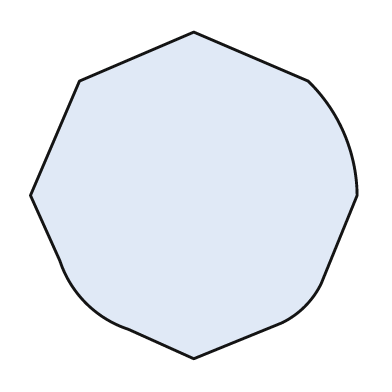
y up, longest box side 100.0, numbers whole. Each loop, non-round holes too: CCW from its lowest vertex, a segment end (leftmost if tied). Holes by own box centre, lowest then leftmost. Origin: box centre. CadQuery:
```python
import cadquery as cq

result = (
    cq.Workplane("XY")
    .moveTo(0.0, -50.0)
    .lineTo(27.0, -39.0)
    .threePointArc((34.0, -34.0), (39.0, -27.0))
    .lineTo(50.0, 0.0)
    .threePointArc((46.0, 19.0), (35.0, 35.0))
    .lineTo(0.0, 50.0)
    .lineTo(-35.0, 35.0)
    .lineTo(-50.0, 0.0)
    .lineTo(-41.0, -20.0)
    .threePointArc((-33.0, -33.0), (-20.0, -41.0))
    .close()
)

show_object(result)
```